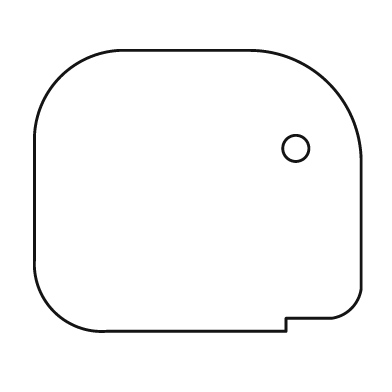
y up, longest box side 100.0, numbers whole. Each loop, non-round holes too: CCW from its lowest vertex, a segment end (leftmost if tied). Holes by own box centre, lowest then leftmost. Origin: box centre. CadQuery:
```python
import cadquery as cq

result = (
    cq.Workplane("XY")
    .moveTo(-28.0, -43.0)
    .lineTo(27.0, -43.0)
    .lineTo(27.0, -39.0)
    .lineTo(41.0, -39.0)
    .threePointArc((47.0, -36.0), (50.0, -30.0))
    .lineTo(50.0, 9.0)
    .threePointArc((40.0, 33.0), (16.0, 43.0))
    .lineTo(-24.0, 43.0)
    .threePointArc((-42.0, 35.0), (-50.0, 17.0))
    .lineTo(-50.0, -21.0)
    .threePointArc((-44.0, -37.0), (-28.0, -43.0))
    .close()
    .moveTo(30.0, 13.0)
    .circle(4.0)
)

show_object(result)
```